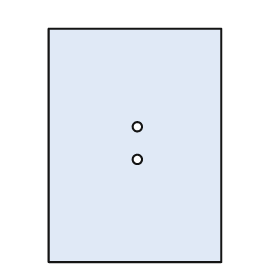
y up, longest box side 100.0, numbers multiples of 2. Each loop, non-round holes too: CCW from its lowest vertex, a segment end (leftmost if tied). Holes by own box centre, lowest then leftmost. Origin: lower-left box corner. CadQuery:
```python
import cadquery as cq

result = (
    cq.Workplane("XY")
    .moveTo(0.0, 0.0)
    .lineTo(74.0, 0.0)
    .lineTo(74.0, 100.0)
    .lineTo(0.0, 100.0)
    .close()
    .moveTo(38.0, 44.0)
    .circle(2.0)
    .moveTo(38.0, 58.0)
    .circle(2.0)
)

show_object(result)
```